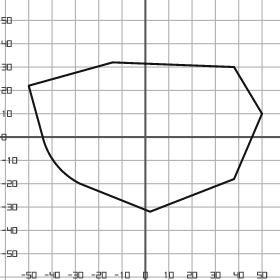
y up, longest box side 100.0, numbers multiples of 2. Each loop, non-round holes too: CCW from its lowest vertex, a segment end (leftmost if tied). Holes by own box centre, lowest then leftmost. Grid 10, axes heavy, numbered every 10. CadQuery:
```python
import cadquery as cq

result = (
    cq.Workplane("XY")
    .moveTo(2.0, -32.0)
    .lineTo(38.0, -18.0)
    .lineTo(50.0, 10.0)
    .lineTo(38.0, 30.0)
    .lineTo(-14.0, 32.0)
    .lineTo(-50.0, 22.0)
    .lineTo(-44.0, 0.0)
    .threePointArc((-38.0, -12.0), (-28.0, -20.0))
    .close()
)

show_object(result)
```